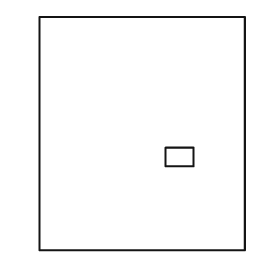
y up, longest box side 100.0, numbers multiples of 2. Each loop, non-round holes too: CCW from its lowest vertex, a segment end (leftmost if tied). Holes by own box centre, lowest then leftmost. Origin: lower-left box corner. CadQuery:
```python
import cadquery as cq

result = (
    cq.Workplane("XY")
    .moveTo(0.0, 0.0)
    .lineTo(88.0, 0.0)
    .lineTo(88.0, 100.0)
    .lineTo(0.0, 100.0)
    .close()
    .moveTo(54.0, 36.0)
    .lineTo(66.0, 36.0)
    .lineTo(66.0, 44.0)
    .lineTo(54.0, 44.0)
    .close()
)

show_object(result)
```